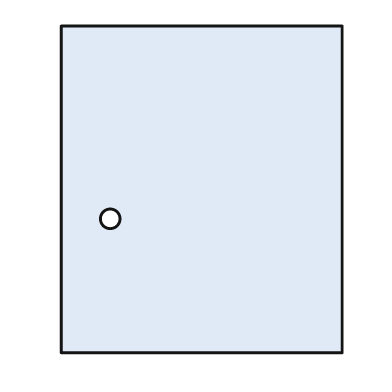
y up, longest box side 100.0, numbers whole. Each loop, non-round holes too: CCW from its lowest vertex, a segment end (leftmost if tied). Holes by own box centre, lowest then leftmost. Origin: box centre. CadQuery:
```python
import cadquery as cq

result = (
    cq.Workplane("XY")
    .moveTo(-43.0, -50.0)
    .lineTo(43.0, -50.0)
    .lineTo(43.0, 50.0)
    .lineTo(-43.0, 50.0)
    .close()
    .moveTo(-28.0, -9.0)
    .circle(3.0)
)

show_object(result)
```